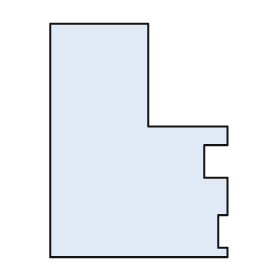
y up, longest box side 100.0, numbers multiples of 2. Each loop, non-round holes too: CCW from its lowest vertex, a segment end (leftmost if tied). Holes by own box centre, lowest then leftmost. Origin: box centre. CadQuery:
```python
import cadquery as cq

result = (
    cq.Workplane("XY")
    .moveTo(-38.0, -50.0)
    .lineTo(38.0, -50.0)
    .lineTo(38.0, -46.0)
    .lineTo(34.0, -46.0)
    .lineTo(34.0, -32.0)
    .lineTo(38.0, -32.0)
    .lineTo(38.0, -16.0)
    .lineTo(28.0, -16.0)
    .lineTo(28.0, -2.0)
    .lineTo(38.0, -2.0)
    .lineTo(38.0, 6.0)
    .lineTo(4.0, 6.0)
    .lineTo(4.0, 50.0)
    .lineTo(-38.0, 50.0)
    .close()
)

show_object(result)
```